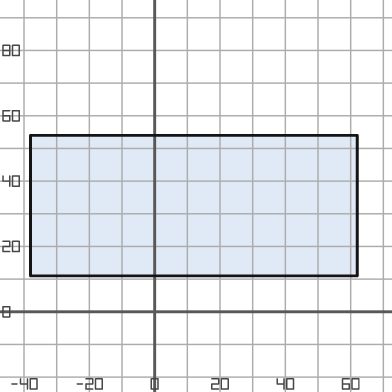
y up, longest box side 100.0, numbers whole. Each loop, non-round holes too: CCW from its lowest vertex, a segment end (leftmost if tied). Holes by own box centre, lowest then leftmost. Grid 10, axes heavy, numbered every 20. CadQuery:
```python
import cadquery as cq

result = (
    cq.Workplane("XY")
    .moveTo(-38.0, 11.0)
    .lineTo(62.0, 11.0)
    .lineTo(62.0, 54.0)
    .lineTo(-38.0, 54.0)
    .close()
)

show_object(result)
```